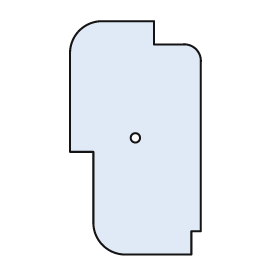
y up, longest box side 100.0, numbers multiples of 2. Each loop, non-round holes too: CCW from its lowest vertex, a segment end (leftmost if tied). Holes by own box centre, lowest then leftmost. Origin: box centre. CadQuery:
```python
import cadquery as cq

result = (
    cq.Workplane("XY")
    .moveTo(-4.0, -50.0)
    .lineTo(24.0, -50.0)
    .lineTo(24.0, -40.0)
    .lineTo(28.0, -40.0)
    .lineTo(28.0, 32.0)
    .threePointArc((26.0, 38.0), (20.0, 40.0))
    .lineTo(8.0, 40.0)
    .lineTo(8.0, 50.0)
    .lineTo(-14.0, 50.0)
    .threePointArc((-24.0, 46.0), (-28.0, 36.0))
    .lineTo(-28.0, -6.0)
    .lineTo(-18.0, -6.0)
    .lineTo(-18.0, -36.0)
    .threePointArc((-14.0, -46.0), (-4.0, -50.0))
    .close()
    .moveTo(0.0, 0.0)
    .circle(2.0)
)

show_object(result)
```